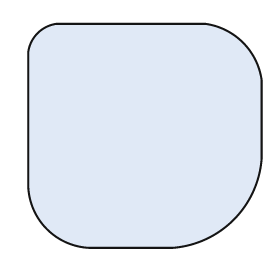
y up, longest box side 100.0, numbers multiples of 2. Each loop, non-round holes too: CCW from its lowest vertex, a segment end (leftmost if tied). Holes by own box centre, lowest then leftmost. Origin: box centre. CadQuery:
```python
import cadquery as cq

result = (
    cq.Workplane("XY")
    .moveTo(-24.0, -48.0)
    .lineTo(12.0, -48.0)
    .threePointArc((38.0, -36.0), (50.0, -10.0))
    .lineTo(50.0, 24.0)
    .threePointArc((42.0, 40.0), (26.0, 48.0))
    .lineTo(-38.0, 48.0)
    .threePointArc((-46.0, 44.0), (-50.0, 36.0))
    .lineTo(-50.0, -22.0)
    .threePointArc((-42.0, -40.0), (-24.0, -48.0))
    .close()
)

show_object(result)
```